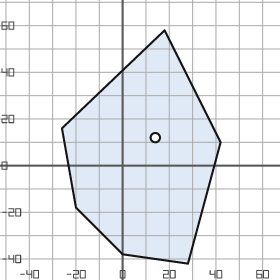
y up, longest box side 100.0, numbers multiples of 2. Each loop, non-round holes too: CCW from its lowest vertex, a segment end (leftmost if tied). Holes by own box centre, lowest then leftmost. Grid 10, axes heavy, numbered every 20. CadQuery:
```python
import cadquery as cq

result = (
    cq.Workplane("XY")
    .moveTo(28.0, -42.0)
    .lineTo(42.0, 10.0)
    .lineTo(18.0, 58.0)
    .lineTo(-26.0, 16.0)
    .lineTo(-20.0, -18.0)
    .lineTo(0.0, -38.0)
    .close()
    .moveTo(14.0, 12.0)
    .circle(2.0)
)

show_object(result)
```